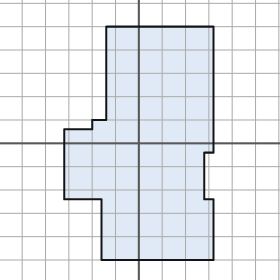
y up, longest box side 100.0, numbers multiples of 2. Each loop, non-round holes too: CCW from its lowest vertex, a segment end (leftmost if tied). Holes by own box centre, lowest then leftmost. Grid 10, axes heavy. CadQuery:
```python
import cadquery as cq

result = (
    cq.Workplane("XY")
    .moveTo(-16.0, -50.0)
    .lineTo(32.0, -50.0)
    .lineTo(32.0, -24.0)
    .lineTo(28.0, -24.0)
    .lineTo(28.0, -4.0)
    .lineTo(32.0, -4.0)
    .lineTo(32.0, 50.0)
    .lineTo(-14.0, 50.0)
    .lineTo(-14.0, 10.0)
    .lineTo(-20.0, 10.0)
    .lineTo(-20.0, 6.0)
    .lineTo(-32.0, 6.0)
    .lineTo(-32.0, -24.0)
    .lineTo(-16.0, -24.0)
    .close()
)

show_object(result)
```